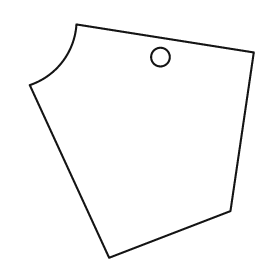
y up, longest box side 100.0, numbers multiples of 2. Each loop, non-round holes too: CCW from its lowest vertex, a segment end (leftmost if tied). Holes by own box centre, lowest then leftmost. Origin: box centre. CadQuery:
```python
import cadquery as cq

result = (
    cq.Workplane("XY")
    .moveTo(-14.0, -50.0)
    .lineTo(38.0, -30.0)
    .lineTo(48.0, 38.0)
    .lineTo(-28.0, 50.0)
    .threePointArc((-34.0, 34.0), (-48.0, 24.0))
    .close()
    .moveTo(8.0, 36.0)
    .circle(4.0)
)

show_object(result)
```